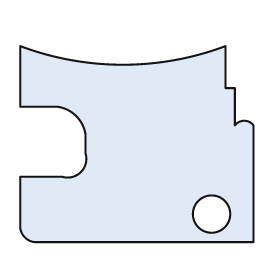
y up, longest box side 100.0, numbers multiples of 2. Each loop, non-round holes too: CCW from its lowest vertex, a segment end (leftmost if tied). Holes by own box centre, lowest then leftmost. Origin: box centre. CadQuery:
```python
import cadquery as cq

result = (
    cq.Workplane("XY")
    .moveTo(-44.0, -42.0)
    .lineTo(50.0, -42.0)
    .lineTo(50.0, 8.0)
    .threePointArc((46.0, 10.0), (42.0, 8.0))
    .lineTo(42.0, 24.0)
    .lineTo(38.0, 24.0)
    .lineTo(38.0, 42.0)
    .threePointArc((-6.0, 34.0), (-50.0, 42.0))
    .lineTo(-50.0, 16.0)
    .lineTo(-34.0, 16.0)
    .threePointArc((-26.0, 12.0), (-22.0, 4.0))
    .lineTo(-22.0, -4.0)
    .threePointArc((-24.0, -12.0), (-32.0, -14.0))
    .lineTo(-50.0, -14.0)
    .lineTo(-50.0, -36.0)
    .threePointArc((-48.0, -40.0), (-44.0, -42.0))
    .close()
    .moveTo(32.0, -30.0)
    .circle(8.0)
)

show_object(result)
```